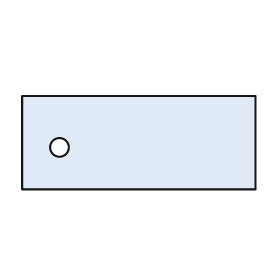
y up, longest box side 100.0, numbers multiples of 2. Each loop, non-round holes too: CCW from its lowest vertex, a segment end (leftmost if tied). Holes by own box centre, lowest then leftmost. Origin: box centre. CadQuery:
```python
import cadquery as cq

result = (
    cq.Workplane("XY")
    .moveTo(-50.0, -20.0)
    .lineTo(50.0, -20.0)
    .lineTo(50.0, 20.0)
    .lineTo(-50.0, 20.0)
    .close()
    .moveTo(-34.0, -2.0)
    .circle(4.0)
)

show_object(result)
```